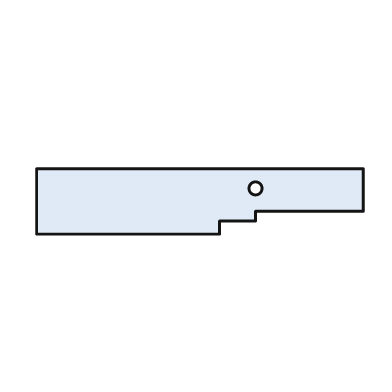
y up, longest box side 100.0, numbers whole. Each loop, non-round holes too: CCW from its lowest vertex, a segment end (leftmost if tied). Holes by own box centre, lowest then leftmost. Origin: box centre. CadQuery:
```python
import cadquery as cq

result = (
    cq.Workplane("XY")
    .moveTo(-50.0, -10.0)
    .lineTo(6.0, -10.0)
    .lineTo(6.0, -6.0)
    .lineTo(17.0, -6.0)
    .lineTo(17.0, -3.0)
    .lineTo(50.0, -3.0)
    .lineTo(50.0, 10.0)
    .lineTo(-50.0, 10.0)
    .close()
    .moveTo(17.0, 4.0)
    .circle(2.0)
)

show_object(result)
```